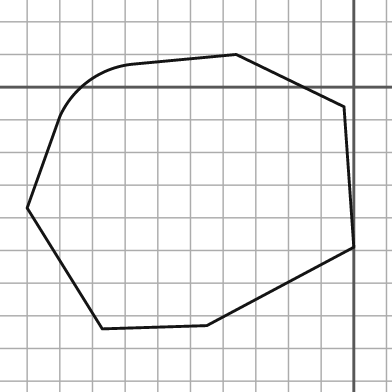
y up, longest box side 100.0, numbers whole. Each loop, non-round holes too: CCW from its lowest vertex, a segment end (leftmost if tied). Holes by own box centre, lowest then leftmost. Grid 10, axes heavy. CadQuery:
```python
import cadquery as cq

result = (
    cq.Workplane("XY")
    .moveTo(-77.0, -74.0)
    .lineTo(-45.0, -73.0)
    .lineTo(0.0, -49.0)
    .lineTo(-3.0, -6.0)
    .lineTo(-36.0, 10.0)
    .lineTo(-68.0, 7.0)
    .threePointArc((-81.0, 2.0), (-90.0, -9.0))
    .lineTo(-100.0, -37.0)
    .close()
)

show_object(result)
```